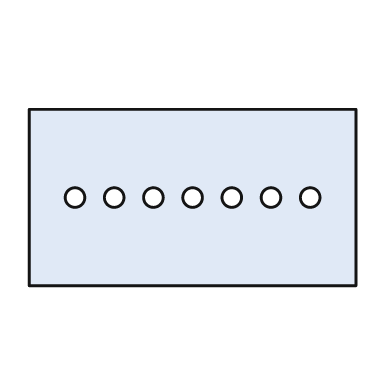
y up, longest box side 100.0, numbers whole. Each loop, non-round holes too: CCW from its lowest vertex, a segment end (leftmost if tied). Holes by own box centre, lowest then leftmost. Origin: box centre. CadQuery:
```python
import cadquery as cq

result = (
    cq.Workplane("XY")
    .moveTo(-50.0, -27.0)
    .lineTo(50.0, -27.0)
    .lineTo(50.0, 27.0)
    .lineTo(-50.0, 27.0)
    .close()
    .moveTo(-36.0, 0.0)
    .circle(3.0)
    .moveTo(-24.0, 0.0)
    .circle(3.0)
    .moveTo(-12.0, 0.0)
    .circle(3.0)
    .moveTo(0.0, 0.0)
    .circle(3.0)
    .moveTo(12.0, 0.0)
    .circle(3.0)
    .moveTo(24.0, 0.0)
    .circle(3.0)
    .moveTo(36.0, 0.0)
    .circle(3.0)
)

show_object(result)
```